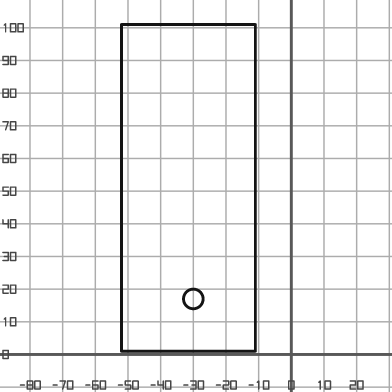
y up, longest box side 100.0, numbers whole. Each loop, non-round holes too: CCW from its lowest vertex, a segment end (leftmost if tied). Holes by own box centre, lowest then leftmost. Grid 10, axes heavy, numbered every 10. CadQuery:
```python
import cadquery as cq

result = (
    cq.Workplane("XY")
    .moveTo(-52.0, 1.0)
    .lineTo(-11.0, 1.0)
    .lineTo(-11.0, 101.0)
    .lineTo(-52.0, 101.0)
    .close()
    .moveTo(-30.0, 17.0)
    .circle(3.0)
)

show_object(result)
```